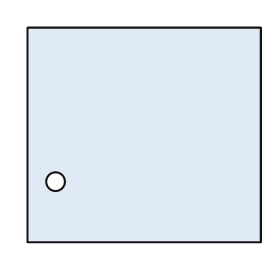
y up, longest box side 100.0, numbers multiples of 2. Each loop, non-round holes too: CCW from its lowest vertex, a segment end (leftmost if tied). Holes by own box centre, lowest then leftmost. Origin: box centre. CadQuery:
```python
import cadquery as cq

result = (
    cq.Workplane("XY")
    .moveTo(-50.0, -46.0)
    .lineTo(50.0, -46.0)
    .lineTo(50.0, 46.0)
    .lineTo(-50.0, 46.0)
    .close()
    .moveTo(-38.0, -20.0)
    .circle(4.0)
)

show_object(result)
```